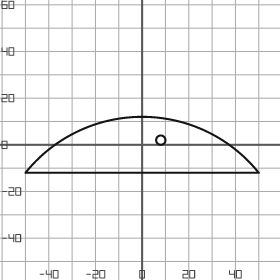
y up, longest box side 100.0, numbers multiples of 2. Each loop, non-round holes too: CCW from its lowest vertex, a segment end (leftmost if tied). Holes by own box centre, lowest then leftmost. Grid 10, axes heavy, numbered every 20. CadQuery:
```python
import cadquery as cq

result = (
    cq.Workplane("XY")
    .moveTo(-50.0, -12.0)
    .lineTo(50.0, -12.0)
    .threePointArc((0.0, 12.0), (-50.0, -12.0))
    .close()
    .moveTo(8.0, 2.0)
    .circle(2.0)
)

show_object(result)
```